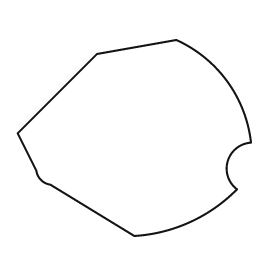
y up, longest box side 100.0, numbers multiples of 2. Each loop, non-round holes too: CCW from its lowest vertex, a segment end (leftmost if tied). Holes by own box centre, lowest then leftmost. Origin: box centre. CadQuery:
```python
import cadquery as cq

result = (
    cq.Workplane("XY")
    .moveTo(0.0, -42.0)
    .threePointArc((24.0, -36.0), (44.0, -22.0))
    .threePointArc((40.0, -10.0), (50.0, -2.0))
    .threePointArc((40.0, 24.0), (18.0, 42.0))
    .lineTo(-16.0, 36.0)
    .lineTo(-50.0, 2.0)
    .lineTo(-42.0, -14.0)
    .threePointArc((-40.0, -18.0), (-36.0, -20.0))
    .close()
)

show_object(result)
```